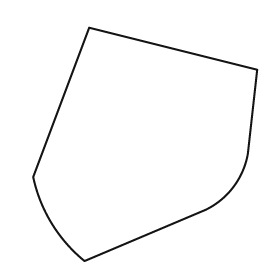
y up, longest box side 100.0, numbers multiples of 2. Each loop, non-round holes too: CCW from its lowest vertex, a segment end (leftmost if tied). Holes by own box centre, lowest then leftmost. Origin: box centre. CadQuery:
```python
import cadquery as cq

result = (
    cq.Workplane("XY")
    .moveTo(-26.0, -50.0)
    .lineTo(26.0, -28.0)
    .threePointArc((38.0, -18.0), (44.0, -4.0))
    .lineTo(48.0, 32.0)
    .lineTo(-24.0, 50.0)
    .lineTo(-48.0, -14.0)
    .threePointArc((-40.0, -34.0), (-26.0, -50.0))
    .close()
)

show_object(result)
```